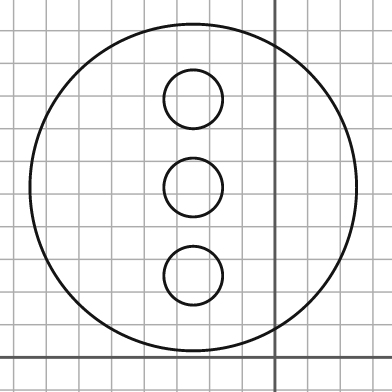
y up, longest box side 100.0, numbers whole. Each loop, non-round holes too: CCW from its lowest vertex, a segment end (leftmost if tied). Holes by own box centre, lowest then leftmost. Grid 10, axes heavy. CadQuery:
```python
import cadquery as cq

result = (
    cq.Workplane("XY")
    .moveTo(-25.0, 52.0)
    .circle(50.0)
    .moveTo(-25.0, 25.0)
    .circle(9.0)
    .moveTo(-25.0, 52.0)
    .circle(9.0)
    .moveTo(-25.0, 79.0)
    .circle(9.0)
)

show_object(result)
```